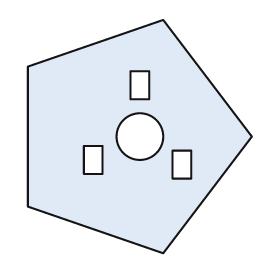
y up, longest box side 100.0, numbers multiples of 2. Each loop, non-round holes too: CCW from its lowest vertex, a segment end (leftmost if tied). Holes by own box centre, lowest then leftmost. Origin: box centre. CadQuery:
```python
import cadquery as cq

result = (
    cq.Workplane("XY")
    .moveTo(10.0, -50.0)
    .lineTo(48.0, 0.0)
    .lineTo(10.0, 50.0)
    .lineTo(-48.0, 30.0)
    .lineTo(-48.0, -30.0)
    .close()
    .moveTo(14.0, -18.0)
    .lineTo(22.0, -18.0)
    .lineTo(22.0, -6.0)
    .lineTo(14.0, -6.0)
    .close()
    .moveTo(-24.0, -16.0)
    .lineTo(-16.0, -16.0)
    .lineTo(-16.0, -4.0)
    .lineTo(-24.0, -4.0)
    .close()
    .moveTo(0.0, 0.0)
    .circle(10.0)
    .moveTo(-4.0, 16.0)
    .lineTo(4.0, 16.0)
    .lineTo(4.0, 28.0)
    .lineTo(-4.0, 28.0)
    .close()
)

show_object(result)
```